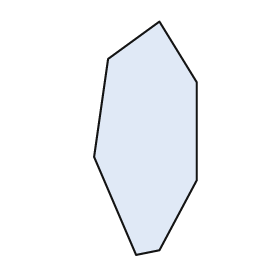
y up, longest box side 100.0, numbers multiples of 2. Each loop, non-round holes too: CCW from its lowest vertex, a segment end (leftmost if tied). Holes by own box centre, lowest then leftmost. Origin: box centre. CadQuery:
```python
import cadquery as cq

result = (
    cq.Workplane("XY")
    .moveTo(-4.0, -50.0)
    .lineTo(6.0, -48.0)
    .lineTo(22.0, -18.0)
    .lineTo(22.0, 24.0)
    .lineTo(6.0, 50.0)
    .lineTo(-16.0, 34.0)
    .lineTo(-22.0, -8.0)
    .close()
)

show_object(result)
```